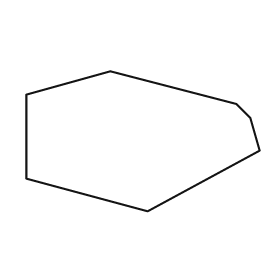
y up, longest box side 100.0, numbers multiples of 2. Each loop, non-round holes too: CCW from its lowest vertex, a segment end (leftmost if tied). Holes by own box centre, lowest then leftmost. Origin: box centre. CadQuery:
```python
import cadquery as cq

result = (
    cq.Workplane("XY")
    .moveTo(2.0, -30.0)
    .lineTo(50.0, -4.0)
    .lineTo(46.0, 10.0)
    .lineTo(40.0, 16.0)
    .lineTo(-14.0, 30.0)
    .lineTo(-50.0, 20.0)
    .lineTo(-50.0, -16.0)
    .close()
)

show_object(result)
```